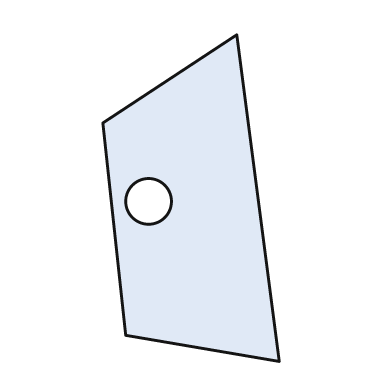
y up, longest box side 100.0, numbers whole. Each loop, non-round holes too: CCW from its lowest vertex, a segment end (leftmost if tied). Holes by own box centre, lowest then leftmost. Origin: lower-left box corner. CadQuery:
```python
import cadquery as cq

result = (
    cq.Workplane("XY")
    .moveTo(54.0, 0.0)
    .lineTo(41.0, 100.0)
    .lineTo(0.0, 73.0)
    .lineTo(7.0, 8.0)
    .close()
    .moveTo(14.0, 49.0)
    .circle(7.0)
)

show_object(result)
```